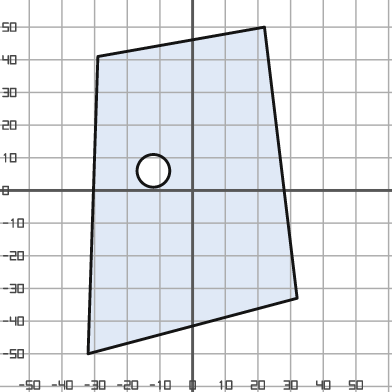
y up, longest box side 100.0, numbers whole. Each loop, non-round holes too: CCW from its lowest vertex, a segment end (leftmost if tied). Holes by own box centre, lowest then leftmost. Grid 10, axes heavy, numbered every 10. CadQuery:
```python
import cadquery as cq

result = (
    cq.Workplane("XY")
    .moveTo(-32.0, -50.0)
    .lineTo(32.0, -33.0)
    .lineTo(22.0, 50.0)
    .lineTo(-29.0, 41.0)
    .close()
    .moveTo(-12.0, 6.0)
    .circle(5.0)
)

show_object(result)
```